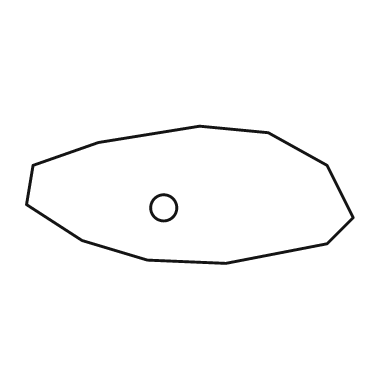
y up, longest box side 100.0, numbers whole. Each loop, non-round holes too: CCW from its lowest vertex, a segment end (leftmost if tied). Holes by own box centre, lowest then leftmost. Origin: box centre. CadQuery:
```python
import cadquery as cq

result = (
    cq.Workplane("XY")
    .moveTo(11.0, -21.0)
    .lineTo(42.0, -15.0)
    .lineTo(50.0, -7.0)
    .lineTo(42.0, 9.0)
    .lineTo(24.0, 19.0)
    .lineTo(3.0, 21.0)
    .lineTo(-28.0, 16.0)
    .lineTo(-48.0, 9.0)
    .lineTo(-50.0, -3.0)
    .lineTo(-33.0, -14.0)
    .lineTo(-13.0, -20.0)
    .close()
    .moveTo(-8.0, -4.0)
    .circle(4.0)
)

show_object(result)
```